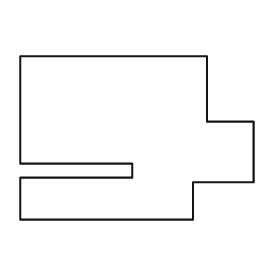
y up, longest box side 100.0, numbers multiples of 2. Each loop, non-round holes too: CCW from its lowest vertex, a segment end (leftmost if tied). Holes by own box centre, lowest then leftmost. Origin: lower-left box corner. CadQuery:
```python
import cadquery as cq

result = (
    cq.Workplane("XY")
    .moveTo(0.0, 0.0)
    .lineTo(74.0, 0.0)
    .lineTo(74.0, 16.0)
    .lineTo(100.0, 16.0)
    .lineTo(100.0, 42.0)
    .lineTo(80.0, 42.0)
    .lineTo(80.0, 70.0)
    .lineTo(0.0, 70.0)
    .lineTo(0.0, 24.0)
    .lineTo(48.0, 24.0)
    .lineTo(48.0, 18.0)
    .lineTo(0.0, 18.0)
    .close()
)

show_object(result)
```